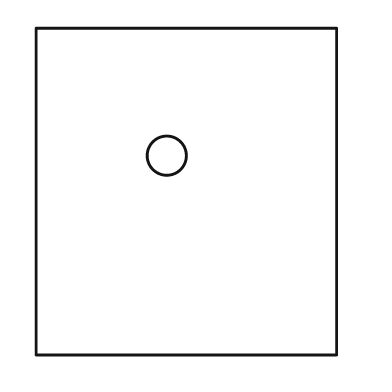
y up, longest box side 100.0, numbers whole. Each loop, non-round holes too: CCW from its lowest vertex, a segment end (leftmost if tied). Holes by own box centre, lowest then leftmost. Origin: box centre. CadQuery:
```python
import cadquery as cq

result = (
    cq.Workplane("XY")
    .moveTo(-46.0, -50.0)
    .lineTo(46.0, -50.0)
    .lineTo(46.0, 50.0)
    .lineTo(-46.0, 50.0)
    .close()
    .moveTo(-6.0, 11.0)
    .circle(6.0)
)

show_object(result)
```